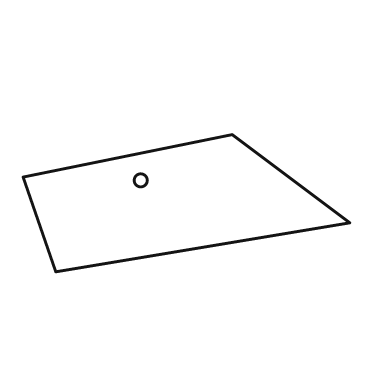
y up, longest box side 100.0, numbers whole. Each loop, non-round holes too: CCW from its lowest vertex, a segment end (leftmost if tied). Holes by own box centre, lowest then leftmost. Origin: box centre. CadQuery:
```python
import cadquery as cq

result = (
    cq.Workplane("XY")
    .moveTo(-40.0, -21.0)
    .lineTo(50.0, -6.0)
    .lineTo(14.0, 21.0)
    .lineTo(-50.0, 8.0)
    .close()
    .moveTo(-14.0, 7.0)
    .circle(2.0)
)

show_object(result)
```